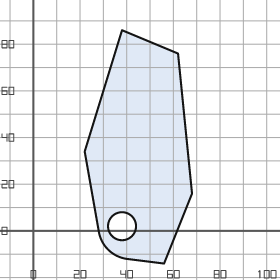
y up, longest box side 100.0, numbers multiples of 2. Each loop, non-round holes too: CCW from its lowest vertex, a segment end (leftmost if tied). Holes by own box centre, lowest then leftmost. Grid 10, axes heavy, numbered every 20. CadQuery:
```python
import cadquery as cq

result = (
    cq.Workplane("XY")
    .moveTo(56.0, -14.0)
    .lineTo(68.0, 16.0)
    .lineTo(62.0, 76.0)
    .lineTo(38.0, 86.0)
    .lineTo(22.0, 34.0)
    .lineTo(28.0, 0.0)
    .threePointArc((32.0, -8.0), (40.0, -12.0))
    .close()
    .moveTo(38.0, 2.0)
    .circle(6.0)
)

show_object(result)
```